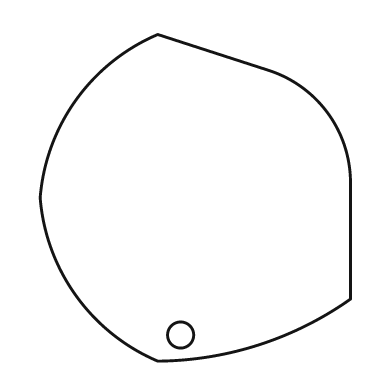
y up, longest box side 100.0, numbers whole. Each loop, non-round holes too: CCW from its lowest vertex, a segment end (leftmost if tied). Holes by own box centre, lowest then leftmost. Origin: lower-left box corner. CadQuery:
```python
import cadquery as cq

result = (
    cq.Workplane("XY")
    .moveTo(36.0, 0.0)
    .threePointArc((67.0, 5.0), (95.0, 19.0))
    .lineTo(95.0, 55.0)
    .threePointArc((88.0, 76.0), (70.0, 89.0))
    .lineTo(36.0, 100.0)
    .threePointArc((11.0, 80.0), (0.0, 50.0))
    .threePointArc((11.0, 20.0), (36.0, 0.0))
    .close()
    .moveTo(43.0, 8.0)
    .circle(4.0)
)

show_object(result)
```